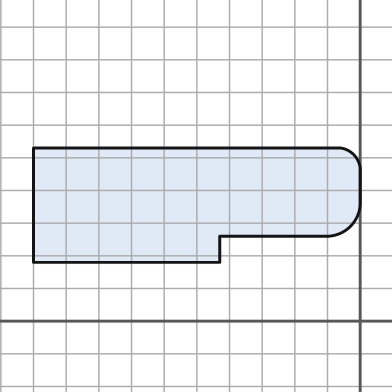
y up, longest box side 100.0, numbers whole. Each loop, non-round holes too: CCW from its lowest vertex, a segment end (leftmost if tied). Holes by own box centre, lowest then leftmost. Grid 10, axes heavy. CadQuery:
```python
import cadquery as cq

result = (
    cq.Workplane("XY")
    .moveTo(-100.0, 18.0)
    .lineTo(-43.0, 18.0)
    .lineTo(-43.0, 26.0)
    .lineTo(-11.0, 26.0)
    .threePointArc((-3.0, 29.0), (0.0, 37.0))
    .lineTo(0.0, 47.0)
    .threePointArc((-2.0, 51.0), (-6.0, 53.0))
    .lineTo(-100.0, 53.0)
    .close()
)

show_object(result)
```